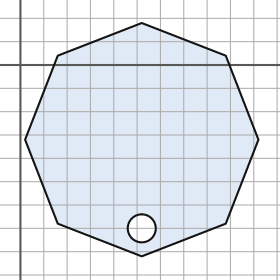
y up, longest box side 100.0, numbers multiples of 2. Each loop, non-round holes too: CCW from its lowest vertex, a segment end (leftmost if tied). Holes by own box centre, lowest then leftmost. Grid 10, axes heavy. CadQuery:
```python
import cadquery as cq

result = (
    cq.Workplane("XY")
    .moveTo(52.0, -82.0)
    .lineTo(88.0, -68.0)
    .lineTo(102.0, -32.0)
    .lineTo(88.0, 4.0)
    .lineTo(52.0, 18.0)
    .lineTo(16.0, 4.0)
    .lineTo(2.0, -32.0)
    .lineTo(16.0, -68.0)
    .close()
    .moveTo(52.0, -70.0)
    .circle(6.0)
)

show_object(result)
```